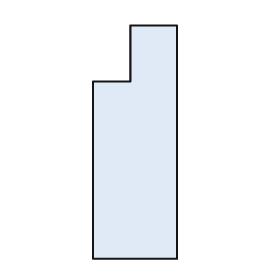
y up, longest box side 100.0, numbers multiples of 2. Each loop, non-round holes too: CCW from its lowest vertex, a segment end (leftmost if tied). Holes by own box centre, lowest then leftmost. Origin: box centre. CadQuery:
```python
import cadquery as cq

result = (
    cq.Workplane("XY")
    .moveTo(-18.0, -50.0)
    .lineTo(18.0, -50.0)
    .lineTo(18.0, 50.0)
    .lineTo(-2.0, 50.0)
    .lineTo(-2.0, 26.0)
    .lineTo(-18.0, 26.0)
    .close()
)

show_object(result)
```